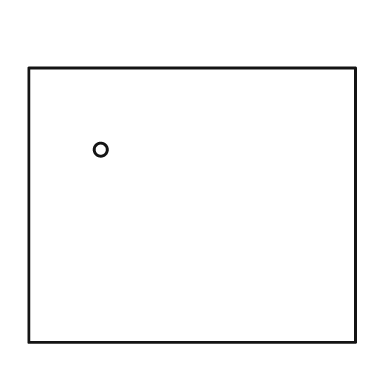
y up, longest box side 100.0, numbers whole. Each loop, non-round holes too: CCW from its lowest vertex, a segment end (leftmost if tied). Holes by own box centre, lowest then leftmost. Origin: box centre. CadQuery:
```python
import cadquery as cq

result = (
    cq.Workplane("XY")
    .moveTo(-50.0, -42.0)
    .lineTo(50.0, -42.0)
    .lineTo(50.0, 42.0)
    .lineTo(-50.0, 42.0)
    .close()
    .moveTo(-28.0, 17.0)
    .circle(2.0)
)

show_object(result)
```